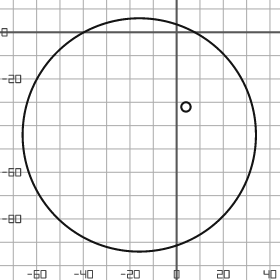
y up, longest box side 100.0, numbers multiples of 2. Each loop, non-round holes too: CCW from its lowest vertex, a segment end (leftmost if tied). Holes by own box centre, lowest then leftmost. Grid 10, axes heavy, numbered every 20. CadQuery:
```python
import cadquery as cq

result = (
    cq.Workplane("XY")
    .moveTo(-16.0, -44.0)
    .circle(50.0)
    .moveTo(4.0, -32.0)
    .circle(2.0)
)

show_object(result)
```